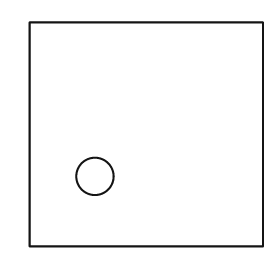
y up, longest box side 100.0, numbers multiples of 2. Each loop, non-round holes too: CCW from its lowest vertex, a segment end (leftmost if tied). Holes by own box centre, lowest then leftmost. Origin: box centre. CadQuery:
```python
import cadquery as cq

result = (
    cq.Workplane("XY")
    .moveTo(-50.0, -48.0)
    .lineTo(50.0, -48.0)
    .lineTo(50.0, 48.0)
    .lineTo(-50.0, 48.0)
    .close()
    .moveTo(-22.0, -18.0)
    .circle(8.0)
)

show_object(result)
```